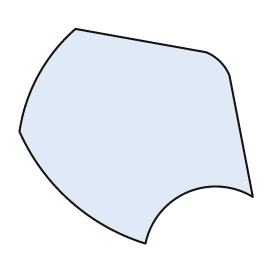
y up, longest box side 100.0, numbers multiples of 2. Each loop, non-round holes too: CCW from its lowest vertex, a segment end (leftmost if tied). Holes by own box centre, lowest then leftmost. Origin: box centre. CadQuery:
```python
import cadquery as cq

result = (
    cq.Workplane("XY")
    .moveTo(4.0, -46.0)
    .threePointArc((22.0, -24.0), (50.0, -26.0))
    .lineTo(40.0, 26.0)
    .threePointArc((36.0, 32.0), (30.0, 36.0))
    .lineTo(-26.0, 46.0)
    .threePointArc((-42.0, 26.0), (-50.0, 2.0))
    .threePointArc((-28.0, -28.0), (4.0, -46.0))
    .close()
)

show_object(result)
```